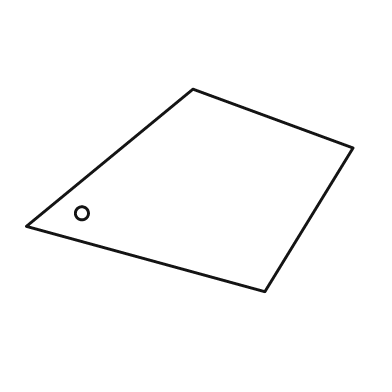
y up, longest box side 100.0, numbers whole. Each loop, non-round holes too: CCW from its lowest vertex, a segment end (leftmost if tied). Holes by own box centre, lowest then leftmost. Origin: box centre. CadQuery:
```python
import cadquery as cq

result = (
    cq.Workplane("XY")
    .moveTo(23.0, -31.0)
    .lineTo(50.0, 13.0)
    .lineTo(1.0, 31.0)
    .lineTo(-50.0, -11.0)
    .close()
    .moveTo(-33.0, -7.0)
    .circle(2.0)
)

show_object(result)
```